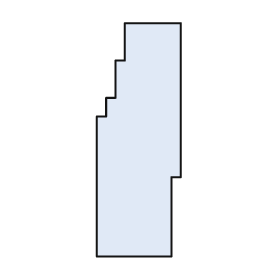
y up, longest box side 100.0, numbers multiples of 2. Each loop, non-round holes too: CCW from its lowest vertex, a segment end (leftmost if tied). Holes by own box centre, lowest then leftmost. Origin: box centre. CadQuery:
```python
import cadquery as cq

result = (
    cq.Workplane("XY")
    .moveTo(-18.0, -50.0)
    .lineTo(14.0, -50.0)
    .lineTo(14.0, -16.0)
    .lineTo(18.0, -16.0)
    .lineTo(18.0, 50.0)
    .lineTo(-6.0, 50.0)
    .lineTo(-6.0, 34.0)
    .lineTo(-10.0, 34.0)
    .lineTo(-10.0, 18.0)
    .lineTo(-14.0, 18.0)
    .lineTo(-14.0, 10.0)
    .lineTo(-18.0, 10.0)
    .close()
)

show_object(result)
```